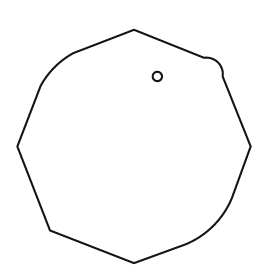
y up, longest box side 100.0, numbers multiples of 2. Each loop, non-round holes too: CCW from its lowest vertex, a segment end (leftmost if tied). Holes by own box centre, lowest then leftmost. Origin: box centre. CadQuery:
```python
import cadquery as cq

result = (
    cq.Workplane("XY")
    .moveTo(0.0, -50.0)
    .lineTo(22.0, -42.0)
    .threePointArc((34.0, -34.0), (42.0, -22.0))
    .lineTo(50.0, 0.0)
    .lineTo(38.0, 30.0)
    .threePointArc((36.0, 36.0), (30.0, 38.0))
    .lineTo(0.0, 50.0)
    .lineTo(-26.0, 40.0)
    .threePointArc((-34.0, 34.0), (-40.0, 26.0))
    .lineTo(-50.0, 0.0)
    .lineTo(-36.0, -36.0)
    .close()
    .moveTo(10.0, 30.0)
    .circle(2.0)
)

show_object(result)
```